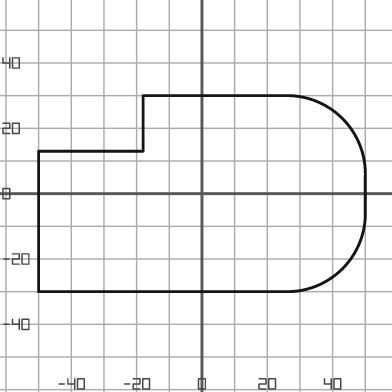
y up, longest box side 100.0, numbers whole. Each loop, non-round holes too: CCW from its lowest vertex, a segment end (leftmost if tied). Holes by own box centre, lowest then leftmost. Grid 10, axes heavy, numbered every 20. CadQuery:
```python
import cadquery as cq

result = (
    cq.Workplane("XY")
    .moveTo(-50.0, -30.0)
    .lineTo(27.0, -30.0)
    .threePointArc((43.0, -23.0), (50.0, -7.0))
    .lineTo(50.0, 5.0)
    .threePointArc((43.0, 23.0), (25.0, 30.0))
    .lineTo(-18.0, 30.0)
    .lineTo(-18.0, 13.0)
    .lineTo(-50.0, 13.0)
    .close()
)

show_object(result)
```